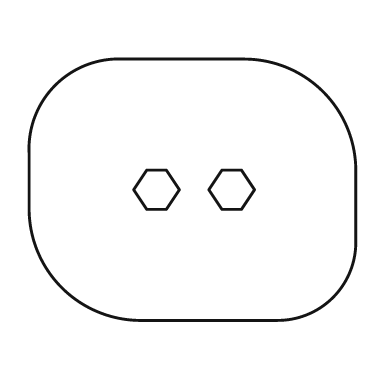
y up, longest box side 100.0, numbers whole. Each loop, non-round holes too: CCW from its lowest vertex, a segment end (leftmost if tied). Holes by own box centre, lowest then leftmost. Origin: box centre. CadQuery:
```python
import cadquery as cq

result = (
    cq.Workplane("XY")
    .moveTo(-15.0, -40.0)
    .lineTo(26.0, -40.0)
    .threePointArc((43.0, -33.0), (50.0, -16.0))
    .lineTo(50.0, 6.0)
    .threePointArc((40.0, 30.0), (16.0, 40.0))
    .lineTo(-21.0, 40.0)
    .threePointArc((-42.0, 32.0), (-50.0, 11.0))
    .lineTo(-50.0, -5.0)
    .threePointArc((-40.0, -30.0), (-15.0, -40.0))
    .close()
    .moveTo(-14.0, -6.0)
    .lineTo(-8.0, -6.0)
    .lineTo(-4.0, 0.0)
    .lineTo(-8.0, 6.0)
    .lineTo(-14.0, 6.0)
    .lineTo(-18.0, 0.0)
    .close()
    .moveTo(9.0, -6.0)
    .lineTo(15.0, -6.0)
    .lineTo(19.0, 0.0)
    .lineTo(15.0, 6.0)
    .lineTo(9.0, 6.0)
    .lineTo(5.0, 0.0)
    .close()
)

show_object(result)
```